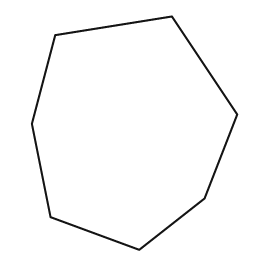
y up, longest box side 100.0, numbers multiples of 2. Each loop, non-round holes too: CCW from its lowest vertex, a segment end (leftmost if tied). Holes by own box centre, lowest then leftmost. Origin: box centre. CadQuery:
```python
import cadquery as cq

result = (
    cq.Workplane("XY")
    .moveTo(2.0, -50.0)
    .lineTo(30.0, -28.0)
    .lineTo(44.0, 8.0)
    .lineTo(16.0, 50.0)
    .lineTo(-34.0, 42.0)
    .lineTo(-44.0, 4.0)
    .lineTo(-36.0, -36.0)
    .close()
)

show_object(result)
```